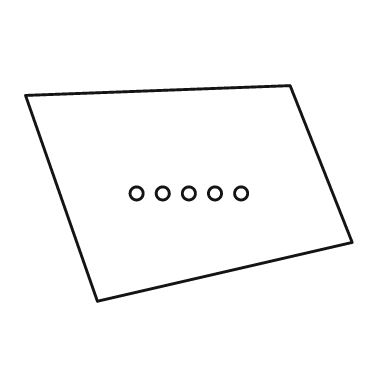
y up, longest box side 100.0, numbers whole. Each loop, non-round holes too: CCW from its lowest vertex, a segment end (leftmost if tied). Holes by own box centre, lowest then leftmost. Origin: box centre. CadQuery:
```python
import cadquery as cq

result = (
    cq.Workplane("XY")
    .moveTo(-28.0, -33.0)
    .lineTo(50.0, -15.0)
    .lineTo(31.0, 33.0)
    .lineTo(-50.0, 30.0)
    .close()
    .moveTo(-16.0, 0.0)
    .circle(2.0)
    .moveTo(-8.0, 0.0)
    .circle(2.0)
    .moveTo(0.0, 0.0)
    .circle(2.0)
    .moveTo(8.0, 0.0)
    .circle(2.0)
    .moveTo(16.0, 0.0)
    .circle(2.0)
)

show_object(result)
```